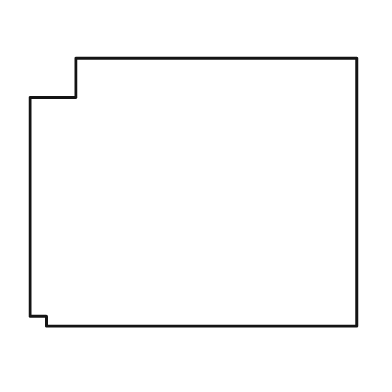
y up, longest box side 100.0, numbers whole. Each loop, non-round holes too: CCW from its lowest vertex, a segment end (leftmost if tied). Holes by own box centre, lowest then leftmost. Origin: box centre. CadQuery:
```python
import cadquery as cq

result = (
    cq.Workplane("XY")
    .moveTo(-45.0, -41.0)
    .lineTo(50.0, -41.0)
    .lineTo(50.0, 41.0)
    .lineTo(-36.0, 41.0)
    .lineTo(-36.0, 29.0)
    .lineTo(-50.0, 29.0)
    .lineTo(-50.0, -38.0)
    .lineTo(-45.0, -38.0)
    .close()
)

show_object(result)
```